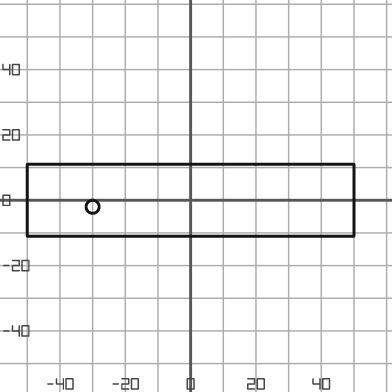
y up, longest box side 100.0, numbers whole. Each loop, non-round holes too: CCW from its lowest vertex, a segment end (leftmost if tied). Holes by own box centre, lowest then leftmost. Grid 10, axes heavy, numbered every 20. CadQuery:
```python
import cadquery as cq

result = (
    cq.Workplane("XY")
    .moveTo(-50.0, -11.0)
    .lineTo(50.0, -11.0)
    .lineTo(50.0, 11.0)
    .lineTo(-50.0, 11.0)
    .close()
    .moveTo(-30.0, -2.0)
    .circle(2.0)
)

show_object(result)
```